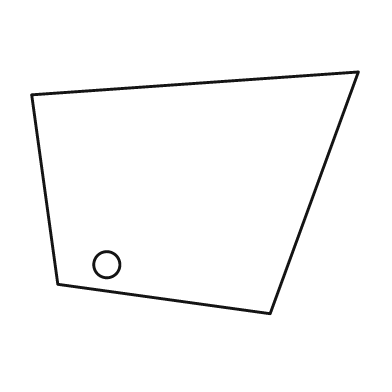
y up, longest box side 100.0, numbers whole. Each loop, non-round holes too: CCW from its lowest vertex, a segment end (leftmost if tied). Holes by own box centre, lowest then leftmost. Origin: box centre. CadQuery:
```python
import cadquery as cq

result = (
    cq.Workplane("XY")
    .moveTo(23.0, -37.0)
    .lineTo(50.0, 37.0)
    .lineTo(-50.0, 30.0)
    .lineTo(-42.0, -28.0)
    .close()
    .moveTo(-27.0, -22.0)
    .circle(4.0)
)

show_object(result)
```